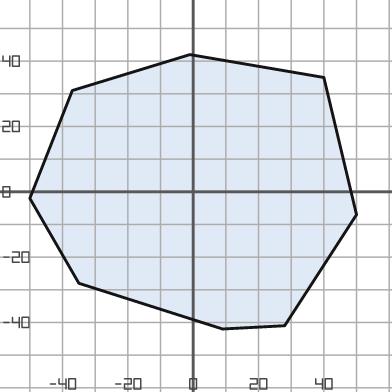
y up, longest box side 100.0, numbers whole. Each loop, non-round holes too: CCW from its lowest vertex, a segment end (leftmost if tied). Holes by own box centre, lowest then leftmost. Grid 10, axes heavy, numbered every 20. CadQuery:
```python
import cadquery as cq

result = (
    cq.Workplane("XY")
    .moveTo(9.0, -42.0)
    .lineTo(28.0, -41.0)
    .lineTo(50.0, -7.0)
    .lineTo(40.0, 35.0)
    .lineTo(-1.0, 42.0)
    .lineTo(-37.0, 31.0)
    .lineTo(-50.0, -2.0)
    .lineTo(-35.0, -28.0)
    .close()
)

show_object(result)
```